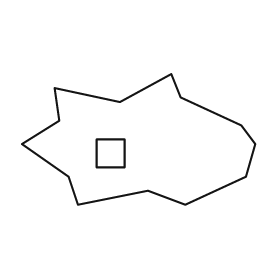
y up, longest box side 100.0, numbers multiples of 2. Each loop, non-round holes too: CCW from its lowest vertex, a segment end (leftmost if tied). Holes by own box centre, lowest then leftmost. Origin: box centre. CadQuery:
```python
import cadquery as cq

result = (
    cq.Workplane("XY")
    .moveTo(-26.0, -28.0)
    .lineTo(4.0, -22.0)
    .lineTo(20.0, -28.0)
    .lineTo(46.0, -16.0)
    .lineTo(50.0, -2.0)
    .lineTo(44.0, 6.0)
    .lineTo(18.0, 18.0)
    .lineTo(14.0, 28.0)
    .lineTo(-8.0, 16.0)
    .lineTo(-36.0, 22.0)
    .lineTo(-34.0, 8.0)
    .lineTo(-50.0, -2.0)
    .lineTo(-30.0, -16.0)
    .close()
    .moveTo(-18.0, -12.0)
    .lineTo(-6.0, -12.0)
    .lineTo(-6.0, 0.0)
    .lineTo(-18.0, 0.0)
    .close()
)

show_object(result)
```